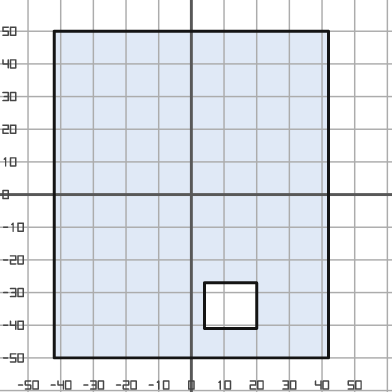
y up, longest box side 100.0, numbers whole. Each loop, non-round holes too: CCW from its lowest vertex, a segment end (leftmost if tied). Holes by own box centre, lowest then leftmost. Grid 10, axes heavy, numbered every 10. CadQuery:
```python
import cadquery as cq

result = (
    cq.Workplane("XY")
    .moveTo(-42.0, -50.0)
    .lineTo(42.0, -50.0)
    .lineTo(42.0, 50.0)
    .lineTo(-42.0, 50.0)
    .close()
    .moveTo(4.0, -41.0)
    .lineTo(20.0, -41.0)
    .lineTo(20.0, -27.0)
    .lineTo(4.0, -27.0)
    .close()
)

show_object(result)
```